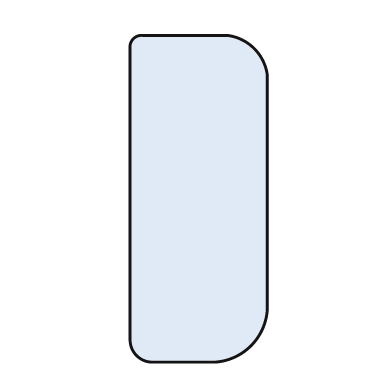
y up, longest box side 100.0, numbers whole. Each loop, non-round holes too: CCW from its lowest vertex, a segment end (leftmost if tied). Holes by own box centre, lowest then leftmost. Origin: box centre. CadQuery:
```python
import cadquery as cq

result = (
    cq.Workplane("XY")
    .moveTo(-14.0, -50.0)
    .lineTo(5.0, -50.0)
    .threePointArc((16.0, -45.0), (21.0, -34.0))
    .lineTo(21.0, 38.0)
    .threePointArc((17.0, 46.0), (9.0, 50.0))
    .lineTo(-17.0, 50.0)
    .threePointArc((-20.0, 49.0), (-21.0, 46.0))
    .lineTo(-21.0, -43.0)
    .threePointArc((-19.0, -48.0), (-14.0, -50.0))
    .close()
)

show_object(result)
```